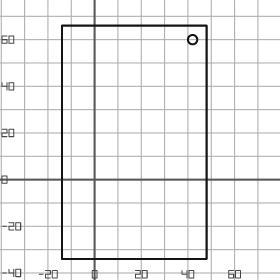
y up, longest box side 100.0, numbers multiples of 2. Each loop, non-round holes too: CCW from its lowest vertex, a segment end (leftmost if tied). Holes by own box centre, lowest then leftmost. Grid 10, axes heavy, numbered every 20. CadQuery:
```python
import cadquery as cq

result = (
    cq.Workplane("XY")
    .moveTo(-14.0, -34.0)
    .lineTo(48.0, -34.0)
    .lineTo(48.0, 66.0)
    .lineTo(-14.0, 66.0)
    .close()
    .moveTo(42.0, 60.0)
    .circle(2.0)
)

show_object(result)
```